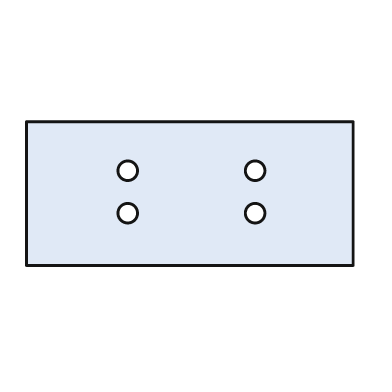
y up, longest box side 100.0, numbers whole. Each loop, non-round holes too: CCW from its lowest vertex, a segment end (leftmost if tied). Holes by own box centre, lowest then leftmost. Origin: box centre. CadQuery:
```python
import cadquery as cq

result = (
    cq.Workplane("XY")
    .moveTo(-50.0, -22.0)
    .lineTo(50.0, -22.0)
    .lineTo(50.0, 22.0)
    .lineTo(-50.0, 22.0)
    .close()
    .moveTo(-19.0, -6.0)
    .circle(3.0)
    .moveTo(20.0, -6.0)
    .circle(3.0)
    .moveTo(-19.0, 7.0)
    .circle(3.0)
    .moveTo(20.0, 7.0)
    .circle(3.0)
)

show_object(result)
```